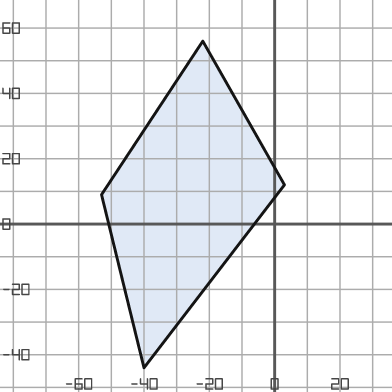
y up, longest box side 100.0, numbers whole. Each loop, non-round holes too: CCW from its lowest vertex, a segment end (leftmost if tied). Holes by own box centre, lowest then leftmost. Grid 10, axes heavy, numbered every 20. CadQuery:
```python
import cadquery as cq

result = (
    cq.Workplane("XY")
    .moveTo(-40.0, -44.0)
    .lineTo(3.0, 12.0)
    .lineTo(-22.0, 56.0)
    .lineTo(-53.0, 9.0)
    .close()
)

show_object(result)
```